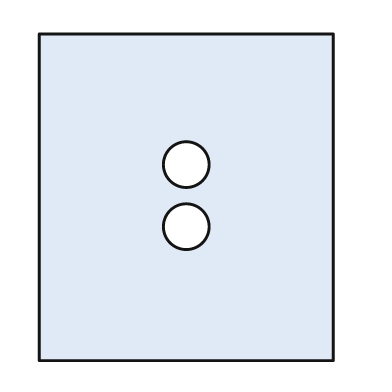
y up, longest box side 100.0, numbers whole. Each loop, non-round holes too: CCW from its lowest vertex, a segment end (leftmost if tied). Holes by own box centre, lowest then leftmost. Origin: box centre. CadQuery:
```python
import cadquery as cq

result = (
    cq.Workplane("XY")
    .moveTo(-45.0, -50.0)
    .lineTo(45.0, -50.0)
    .lineTo(45.0, 50.0)
    .lineTo(-45.0, 50.0)
    .close()
    .moveTo(0.0, -9.0)
    .circle(7.0)
    .moveTo(0.0, 10.0)
    .circle(7.0)
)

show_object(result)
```